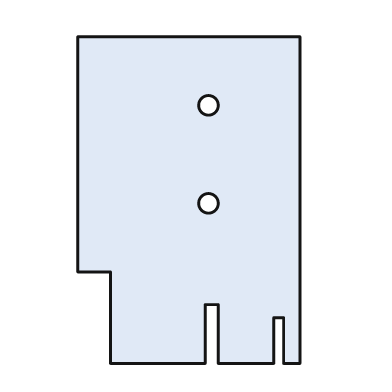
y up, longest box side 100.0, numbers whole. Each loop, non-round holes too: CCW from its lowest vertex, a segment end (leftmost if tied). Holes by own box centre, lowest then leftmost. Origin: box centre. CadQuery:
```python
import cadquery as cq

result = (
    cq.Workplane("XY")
    .moveTo(-24.0, -50.0)
    .lineTo(5.0, -50.0)
    .lineTo(5.0, -32.0)
    .lineTo(9.0, -32.0)
    .lineTo(9.0, -50.0)
    .lineTo(26.0, -50.0)
    .lineTo(26.0, -36.0)
    .lineTo(29.0, -36.0)
    .lineTo(29.0, -50.0)
    .lineTo(34.0, -50.0)
    .lineTo(34.0, 50.0)
    .lineTo(-34.0, 50.0)
    .lineTo(-34.0, -22.0)
    .lineTo(-24.0, -22.0)
    .close()
    .moveTo(6.0, -1.0)
    .circle(3.0)
    .moveTo(6.0, 29.0)
    .circle(3.0)
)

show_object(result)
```